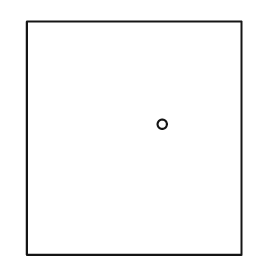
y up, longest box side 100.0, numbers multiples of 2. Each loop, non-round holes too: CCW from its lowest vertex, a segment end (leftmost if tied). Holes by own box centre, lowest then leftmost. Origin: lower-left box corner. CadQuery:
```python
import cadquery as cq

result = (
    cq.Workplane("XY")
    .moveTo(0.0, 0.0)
    .lineTo(92.0, 0.0)
    .lineTo(92.0, 100.0)
    .lineTo(0.0, 100.0)
    .close()
    .moveTo(58.0, 56.0)
    .circle(2.0)
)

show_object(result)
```